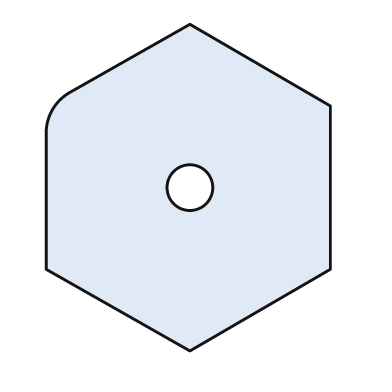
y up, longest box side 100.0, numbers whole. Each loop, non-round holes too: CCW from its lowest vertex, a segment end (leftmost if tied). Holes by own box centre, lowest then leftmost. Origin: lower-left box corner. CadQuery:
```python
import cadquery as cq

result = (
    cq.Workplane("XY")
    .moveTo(44.0, 0.0)
    .lineTo(87.0, 25.0)
    .lineTo(87.0, 75.0)
    .lineTo(44.0, 100.0)
    .lineTo(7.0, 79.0)
    .threePointArc((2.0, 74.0), (0.0, 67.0))
    .lineTo(0.0, 25.0)
    .close()
    .moveTo(44.0, 50.0)
    .circle(7.0)
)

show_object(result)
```